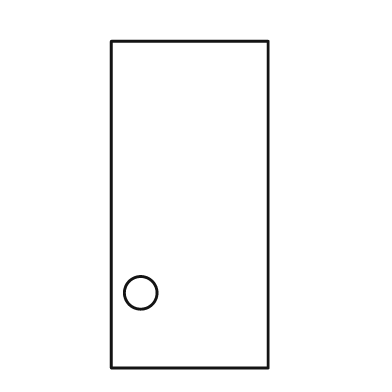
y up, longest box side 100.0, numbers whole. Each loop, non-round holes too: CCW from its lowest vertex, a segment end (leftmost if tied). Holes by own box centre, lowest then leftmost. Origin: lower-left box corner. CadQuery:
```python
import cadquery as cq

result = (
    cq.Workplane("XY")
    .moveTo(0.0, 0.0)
    .lineTo(48.0, 0.0)
    .lineTo(48.0, 100.0)
    .lineTo(0.0, 100.0)
    .close()
    .moveTo(9.0, 23.0)
    .circle(5.0)
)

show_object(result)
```